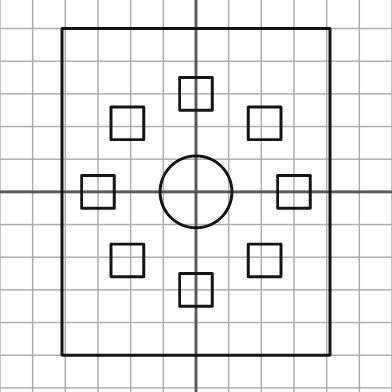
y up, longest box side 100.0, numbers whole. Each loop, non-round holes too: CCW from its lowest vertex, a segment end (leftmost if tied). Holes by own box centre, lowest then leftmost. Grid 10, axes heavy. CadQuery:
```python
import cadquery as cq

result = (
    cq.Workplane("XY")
    .moveTo(-41.0, -50.0)
    .lineTo(41.0, -50.0)
    .lineTo(41.0, 50.0)
    .lineTo(-41.0, 50.0)
    .close()
    .moveTo(-5.0, -35.0)
    .lineTo(5.0, -35.0)
    .lineTo(5.0, -25.0)
    .lineTo(-5.0, -25.0)
    .close()
    .moveTo(-26.0, -26.0)
    .lineTo(-16.0, -26.0)
    .lineTo(-16.0, -16.0)
    .lineTo(-26.0, -16.0)
    .close()
    .moveTo(16.0, -26.0)
    .lineTo(26.0, -26.0)
    .lineTo(26.0, -16.0)
    .lineTo(16.0, -16.0)
    .close()
    .moveTo(-35.0, -5.0)
    .lineTo(-25.0, -5.0)
    .lineTo(-25.0, 5.0)
    .lineTo(-35.0, 5.0)
    .close()
    .moveTo(0.0, 0.0)
    .circle(11.0)
    .moveTo(25.0, -5.0)
    .lineTo(35.0, -5.0)
    .lineTo(35.0, 5.0)
    .lineTo(25.0, 5.0)
    .close()
    .moveTo(-26.0, 16.0)
    .lineTo(-16.0, 16.0)
    .lineTo(-16.0, 26.0)
    .lineTo(-26.0, 26.0)
    .close()
    .moveTo(16.0, 16.0)
    .lineTo(26.0, 16.0)
    .lineTo(26.0, 26.0)
    .lineTo(16.0, 26.0)
    .close()
    .moveTo(-5.0, 25.0)
    .lineTo(5.0, 25.0)
    .lineTo(5.0, 35.0)
    .lineTo(-5.0, 35.0)
    .close()
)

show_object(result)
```